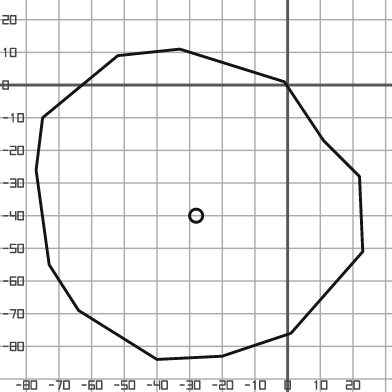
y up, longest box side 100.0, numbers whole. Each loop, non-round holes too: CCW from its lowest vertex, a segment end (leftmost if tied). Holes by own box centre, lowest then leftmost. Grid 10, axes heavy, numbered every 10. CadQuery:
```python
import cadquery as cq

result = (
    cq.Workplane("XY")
    .moveTo(-40.0, -84.0)
    .lineTo(-20.0, -83.0)
    .lineTo(1.0, -76.0)
    .lineTo(23.0, -51.0)
    .lineTo(22.0, -28.0)
    .lineTo(11.0, -17.0)
    .lineTo(-1.0, 1.0)
    .lineTo(-33.0, 11.0)
    .lineTo(-52.0, 9.0)
    .lineTo(-75.0, -10.0)
    .lineTo(-77.0, -26.0)
    .lineTo(-73.0, -55.0)
    .lineTo(-64.0, -69.0)
    .close()
    .moveTo(-28.0, -40.0)
    .circle(2.0)
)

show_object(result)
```